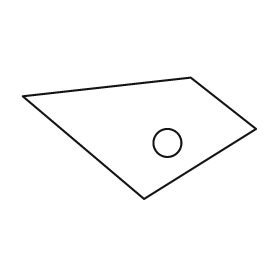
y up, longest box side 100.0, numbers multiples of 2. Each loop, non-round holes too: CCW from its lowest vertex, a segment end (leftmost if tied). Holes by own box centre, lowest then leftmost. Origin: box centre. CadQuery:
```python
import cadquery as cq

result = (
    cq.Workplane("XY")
    .moveTo(2.0, -26.0)
    .lineTo(50.0, 4.0)
    .lineTo(22.0, 26.0)
    .lineTo(-50.0, 18.0)
    .close()
    .moveTo(12.0, -2.0)
    .circle(6.0)
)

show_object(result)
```